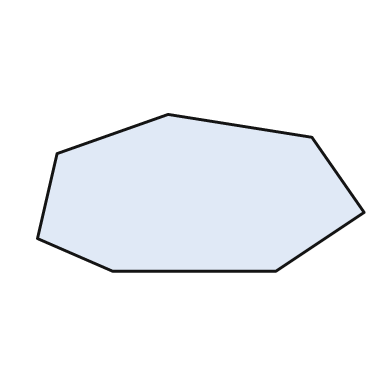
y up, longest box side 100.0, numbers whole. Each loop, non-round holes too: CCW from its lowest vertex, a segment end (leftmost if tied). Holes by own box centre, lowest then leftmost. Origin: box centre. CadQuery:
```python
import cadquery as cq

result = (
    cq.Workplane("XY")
    .moveTo(-27.0, -24.0)
    .lineTo(23.0, -24.0)
    .lineTo(50.0, -6.0)
    .lineTo(34.0, 17.0)
    .lineTo(-10.0, 24.0)
    .lineTo(-44.0, 12.0)
    .lineTo(-50.0, -14.0)
    .close()
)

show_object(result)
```